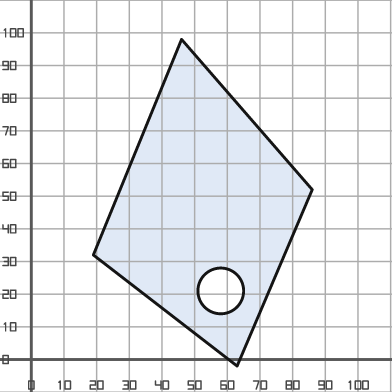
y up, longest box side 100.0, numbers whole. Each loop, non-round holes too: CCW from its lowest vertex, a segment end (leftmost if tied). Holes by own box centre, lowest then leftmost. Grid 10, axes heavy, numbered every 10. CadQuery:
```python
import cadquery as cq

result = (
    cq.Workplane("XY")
    .moveTo(63.0, -2.0)
    .lineTo(86.0, 52.0)
    .lineTo(46.0, 98.0)
    .lineTo(19.0, 32.0)
    .close()
    .moveTo(58.0, 21.0)
    .circle(7.0)
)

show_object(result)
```